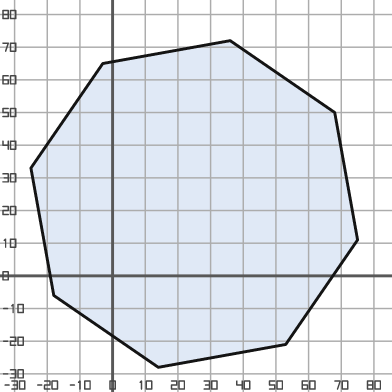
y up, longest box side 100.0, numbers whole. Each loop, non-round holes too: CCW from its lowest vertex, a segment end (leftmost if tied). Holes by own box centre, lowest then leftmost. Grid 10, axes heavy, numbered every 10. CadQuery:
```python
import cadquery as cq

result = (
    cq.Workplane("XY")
    .moveTo(14.0, -28.0)
    .lineTo(53.0, -21.0)
    .lineTo(75.0, 11.0)
    .lineTo(68.0, 50.0)
    .lineTo(36.0, 72.0)
    .lineTo(-3.0, 65.0)
    .lineTo(-25.0, 33.0)
    .lineTo(-18.0, -6.0)
    .close()
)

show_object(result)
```